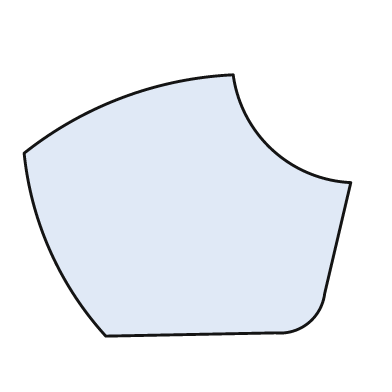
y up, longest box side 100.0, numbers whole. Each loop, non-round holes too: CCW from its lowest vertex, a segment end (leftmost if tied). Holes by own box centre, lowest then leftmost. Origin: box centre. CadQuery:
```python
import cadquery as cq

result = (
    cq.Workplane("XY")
    .moveTo(-25.0, -40.0)
    .lineTo(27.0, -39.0)
    .threePointArc((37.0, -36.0), (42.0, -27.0))
    .lineTo(50.0, 7.0)
    .threePointArc((26.0, 17.0), (14.0, 40.0))
    .threePointArc((-20.0, 33.0), (-50.0, 16.0))
    .threePointArc((-42.0, -14.0), (-25.0, -40.0))
    .close()
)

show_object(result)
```